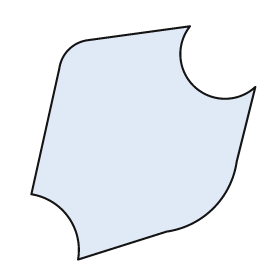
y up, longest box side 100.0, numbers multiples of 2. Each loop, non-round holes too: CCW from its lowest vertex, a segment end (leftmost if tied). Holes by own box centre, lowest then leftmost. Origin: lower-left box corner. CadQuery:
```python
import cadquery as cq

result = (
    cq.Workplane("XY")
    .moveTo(20.0, 0.0)
    .lineTo(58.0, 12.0)
    .threePointArc((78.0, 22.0), (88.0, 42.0))
    .lineTo(96.0, 74.0)
    .threePointArc((70.0, 74.0), (68.0, 100.0))
    .lineTo(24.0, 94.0)
    .threePointArc((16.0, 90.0), (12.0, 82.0))
    .lineTo(0.0, 28.0)
    .threePointArc((16.0, 18.0), (20.0, 0.0))
    .close()
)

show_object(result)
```